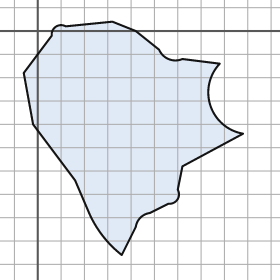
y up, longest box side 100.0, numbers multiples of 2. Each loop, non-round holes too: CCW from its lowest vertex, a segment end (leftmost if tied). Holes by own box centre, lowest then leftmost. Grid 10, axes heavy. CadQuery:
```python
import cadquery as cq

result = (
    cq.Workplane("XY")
    .moveTo(36.0, -96.0)
    .lineTo(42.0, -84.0)
    .threePointArc((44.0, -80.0), (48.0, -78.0))
    .lineTo(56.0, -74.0)
    .threePointArc((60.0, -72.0), (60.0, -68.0))
    .lineTo(62.0, -58.0)
    .lineTo(88.0, -44.0)
    .threePointArc((74.0, -32.0), (78.0, -14.0))
    .lineTo(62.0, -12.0)
    .threePointArc((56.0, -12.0), (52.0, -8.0))
    .lineTo(42.0, 0.0)
    .lineTo(32.0, 4.0)
    .lineTo(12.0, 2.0)
    .threePointArc((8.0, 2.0), (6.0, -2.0))
    .lineTo(-6.0, -18.0)
    .lineTo(-2.0, -40.0)
    .lineTo(16.0, -64.0)
    .lineTo(22.0, -78.0)
    .threePointArc((28.0, -88.0), (36.0, -96.0))
    .close()
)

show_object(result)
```